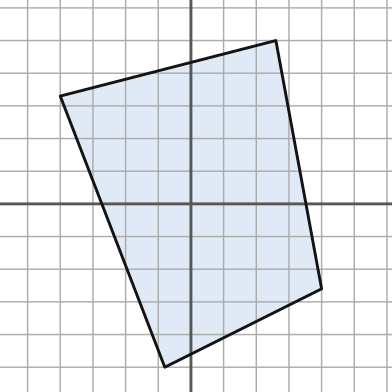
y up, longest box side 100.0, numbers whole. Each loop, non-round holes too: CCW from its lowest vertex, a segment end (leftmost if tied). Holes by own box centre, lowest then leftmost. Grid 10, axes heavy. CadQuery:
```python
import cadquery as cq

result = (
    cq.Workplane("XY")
    .moveTo(-8.0, -50.0)
    .lineTo(40.0, -26.0)
    .lineTo(26.0, 50.0)
    .lineTo(-40.0, 33.0)
    .close()
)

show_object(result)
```